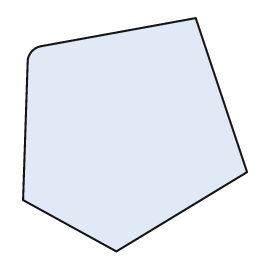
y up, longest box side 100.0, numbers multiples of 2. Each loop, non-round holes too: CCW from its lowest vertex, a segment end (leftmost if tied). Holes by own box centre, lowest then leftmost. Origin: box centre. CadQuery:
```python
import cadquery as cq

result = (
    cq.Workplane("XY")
    .moveTo(-8.0, -50.0)
    .lineTo(48.0, -16.0)
    .lineTo(26.0, 50.0)
    .lineTo(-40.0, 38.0)
    .threePointArc((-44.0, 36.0), (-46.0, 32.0))
    .lineTo(-48.0, -28.0)
    .close()
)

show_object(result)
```